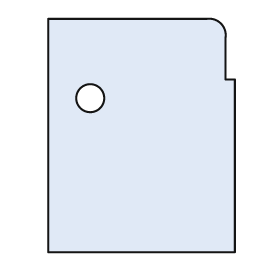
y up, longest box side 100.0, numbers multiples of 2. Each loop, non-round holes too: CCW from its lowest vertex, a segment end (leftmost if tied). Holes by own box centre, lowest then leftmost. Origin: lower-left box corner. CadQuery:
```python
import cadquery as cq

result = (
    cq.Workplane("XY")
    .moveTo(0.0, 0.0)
    .lineTo(80.0, 0.0)
    .lineTo(80.0, 74.0)
    .lineTo(76.0, 74.0)
    .lineTo(76.0, 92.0)
    .threePointArc((74.0, 98.0), (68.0, 100.0))
    .lineTo(0.0, 100.0)
    .close()
    .moveTo(18.0, 66.0)
    .circle(6.0)
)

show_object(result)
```